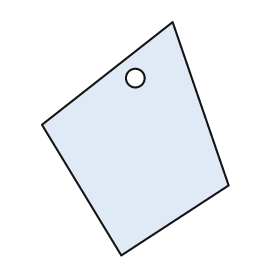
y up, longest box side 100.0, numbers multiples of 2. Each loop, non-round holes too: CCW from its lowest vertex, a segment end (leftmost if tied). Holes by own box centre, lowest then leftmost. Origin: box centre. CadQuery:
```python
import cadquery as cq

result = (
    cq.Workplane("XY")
    .moveTo(-6.0, -50.0)
    .lineTo(40.0, -20.0)
    .lineTo(16.0, 50.0)
    .lineTo(-40.0, 6.0)
    .close()
    .moveTo(0.0, 26.0)
    .circle(4.0)
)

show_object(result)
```